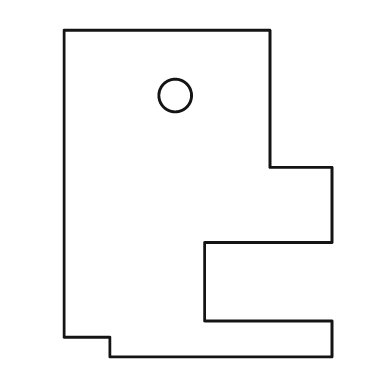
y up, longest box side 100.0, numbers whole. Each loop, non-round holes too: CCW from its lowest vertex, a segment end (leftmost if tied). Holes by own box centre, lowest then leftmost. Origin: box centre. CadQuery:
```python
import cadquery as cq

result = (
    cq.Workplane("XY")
    .moveTo(-27.0, -50.0)
    .lineTo(41.0, -50.0)
    .lineTo(41.0, -39.0)
    .lineTo(2.0, -39.0)
    .lineTo(2.0, -15.0)
    .lineTo(41.0, -15.0)
    .lineTo(41.0, 8.0)
    .lineTo(22.0, 8.0)
    .lineTo(22.0, 50.0)
    .lineTo(-41.0, 50.0)
    .lineTo(-41.0, -44.0)
    .lineTo(-27.0, -44.0)
    .close()
    .moveTo(-7.0, 30.0)
    .circle(5.0)
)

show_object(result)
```